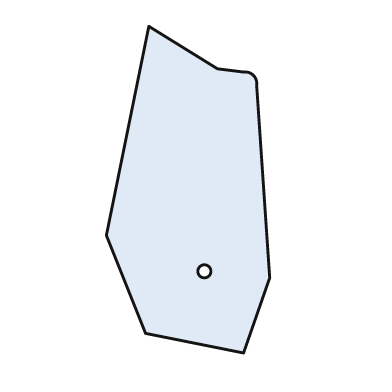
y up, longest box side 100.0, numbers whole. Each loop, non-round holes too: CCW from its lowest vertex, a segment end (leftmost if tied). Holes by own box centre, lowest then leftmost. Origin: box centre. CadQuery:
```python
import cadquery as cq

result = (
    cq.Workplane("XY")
    .moveTo(17.0, -50.0)
    .lineTo(25.0, -27.0)
    .lineTo(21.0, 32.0)
    .threePointArc((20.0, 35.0), (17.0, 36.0))
    .lineTo(9.0, 37.0)
    .lineTo(-12.0, 50.0)
    .lineTo(-25.0, -14.0)
    .lineTo(-13.0, -44.0)
    .close()
    .moveTo(5.0, -25.0)
    .circle(2.0)
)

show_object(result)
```